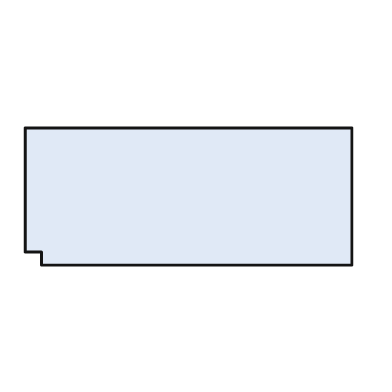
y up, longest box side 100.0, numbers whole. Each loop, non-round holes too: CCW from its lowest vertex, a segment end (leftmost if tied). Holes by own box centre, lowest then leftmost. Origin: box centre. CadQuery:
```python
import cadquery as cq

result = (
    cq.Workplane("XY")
    .moveTo(-45.0, -21.0)
    .lineTo(50.0, -21.0)
    .lineTo(50.0, 21.0)
    .lineTo(-50.0, 21.0)
    .lineTo(-50.0, -17.0)
    .lineTo(-45.0, -17.0)
    .close()
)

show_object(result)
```